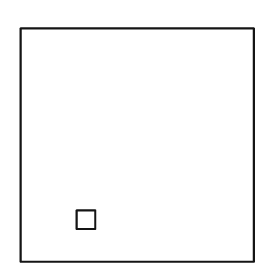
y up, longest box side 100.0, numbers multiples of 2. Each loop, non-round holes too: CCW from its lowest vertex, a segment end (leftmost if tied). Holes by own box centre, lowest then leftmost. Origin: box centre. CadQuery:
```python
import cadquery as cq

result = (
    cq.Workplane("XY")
    .moveTo(-50.0, -50.0)
    .lineTo(50.0, -50.0)
    .lineTo(50.0, 50.0)
    .lineTo(-50.0, 50.0)
    .close()
    .moveTo(-26.0, -36.0)
    .lineTo(-18.0, -36.0)
    .lineTo(-18.0, -28.0)
    .lineTo(-26.0, -28.0)
    .close()
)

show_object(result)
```